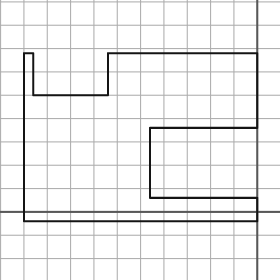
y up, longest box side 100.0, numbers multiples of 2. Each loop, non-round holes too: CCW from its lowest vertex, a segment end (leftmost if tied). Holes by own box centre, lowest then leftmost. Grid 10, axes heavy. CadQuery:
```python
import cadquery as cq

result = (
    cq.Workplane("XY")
    .moveTo(-100.0, -4.0)
    .lineTo(0.0, -4.0)
    .lineTo(0.0, 6.0)
    .lineTo(-46.0, 6.0)
    .lineTo(-46.0, 36.0)
    .lineTo(0.0, 36.0)
    .lineTo(0.0, 68.0)
    .lineTo(-64.0, 68.0)
    .lineTo(-64.0, 50.0)
    .lineTo(-96.0, 50.0)
    .lineTo(-96.0, 68.0)
    .lineTo(-100.0, 68.0)
    .close()
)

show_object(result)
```